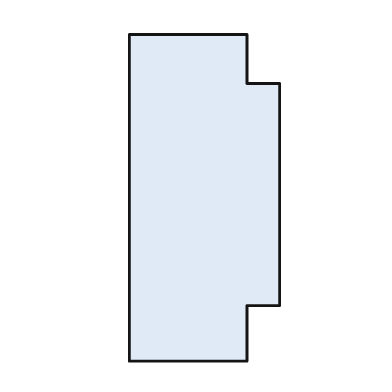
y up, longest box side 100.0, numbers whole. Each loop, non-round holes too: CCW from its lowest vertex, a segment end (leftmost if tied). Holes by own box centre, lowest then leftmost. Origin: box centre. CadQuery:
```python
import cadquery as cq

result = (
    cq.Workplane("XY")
    .moveTo(-23.0, -50.0)
    .lineTo(13.0, -50.0)
    .lineTo(13.0, -33.0)
    .lineTo(23.0, -33.0)
    .lineTo(23.0, 35.0)
    .lineTo(13.0, 35.0)
    .lineTo(13.0, 50.0)
    .lineTo(-23.0, 50.0)
    .close()
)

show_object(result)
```